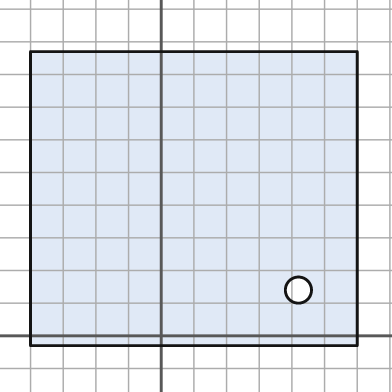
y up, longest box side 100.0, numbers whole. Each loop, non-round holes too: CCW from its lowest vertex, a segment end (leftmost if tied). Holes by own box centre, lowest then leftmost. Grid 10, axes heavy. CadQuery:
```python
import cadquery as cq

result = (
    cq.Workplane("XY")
    .moveTo(-40.0, -3.0)
    .lineTo(60.0, -3.0)
    .lineTo(60.0, 87.0)
    .lineTo(-40.0, 87.0)
    .close()
    .moveTo(42.0, 14.0)
    .circle(4.0)
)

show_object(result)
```